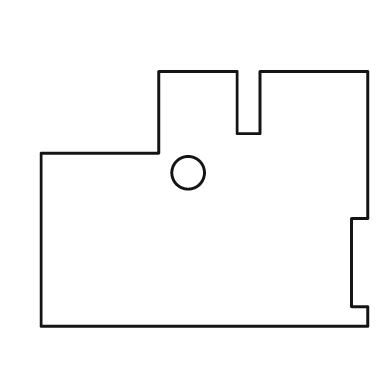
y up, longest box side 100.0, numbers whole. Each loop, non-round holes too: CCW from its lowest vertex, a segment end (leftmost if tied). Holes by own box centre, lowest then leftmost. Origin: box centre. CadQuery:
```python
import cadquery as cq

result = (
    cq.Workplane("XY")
    .moveTo(-50.0, -39.0)
    .lineTo(50.0, -39.0)
    .lineTo(50.0, -33.0)
    .lineTo(45.0, -33.0)
    .lineTo(45.0, -6.0)
    .lineTo(50.0, -6.0)
    .lineTo(50.0, 39.0)
    .lineTo(17.0, 39.0)
    .lineTo(17.0, 20.0)
    .lineTo(10.0, 20.0)
    .lineTo(10.0, 39.0)
    .lineTo(-14.0, 39.0)
    .lineTo(-14.0, 14.0)
    .lineTo(-50.0, 14.0)
    .close()
    .moveTo(-5.0, 8.0)
    .circle(5.0)
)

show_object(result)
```